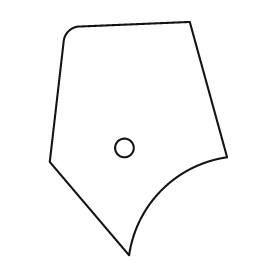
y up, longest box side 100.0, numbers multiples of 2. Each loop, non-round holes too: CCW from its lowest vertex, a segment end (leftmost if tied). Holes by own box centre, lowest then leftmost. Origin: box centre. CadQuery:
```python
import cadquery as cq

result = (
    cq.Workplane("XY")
    .moveTo(-4.0, -50.0)
    .threePointArc((10.0, -22.0), (38.0, -8.0))
    .lineTo(22.0, 50.0)
    .lineTo(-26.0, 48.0)
    .threePointArc((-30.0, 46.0), (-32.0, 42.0))
    .lineTo(-38.0, -10.0)
    .close()
    .moveTo(-6.0, -4.0)
    .circle(4.0)
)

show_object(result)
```